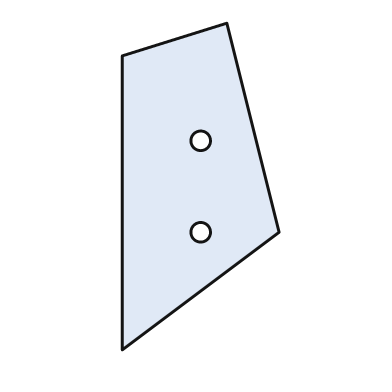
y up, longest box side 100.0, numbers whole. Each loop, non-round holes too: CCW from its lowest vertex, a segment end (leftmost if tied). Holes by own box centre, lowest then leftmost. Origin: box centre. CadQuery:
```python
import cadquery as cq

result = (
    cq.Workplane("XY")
    .moveTo(-24.0, -50.0)
    .lineTo(24.0, -14.0)
    .lineTo(8.0, 50.0)
    .lineTo(-24.0, 40.0)
    .close()
    .moveTo(0.0, -14.0)
    .circle(3.0)
    .moveTo(0.0, 14.0)
    .circle(3.0)
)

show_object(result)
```